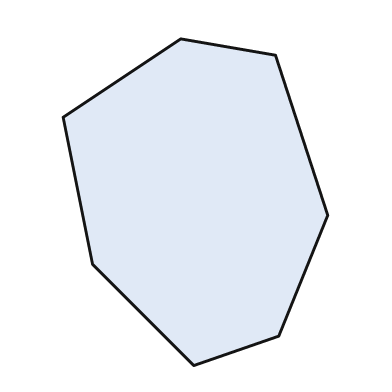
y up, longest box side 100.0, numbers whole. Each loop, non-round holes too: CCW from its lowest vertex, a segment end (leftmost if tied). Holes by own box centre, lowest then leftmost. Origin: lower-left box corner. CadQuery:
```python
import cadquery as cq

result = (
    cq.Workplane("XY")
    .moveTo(40.0, 0.0)
    .lineTo(66.0, 9.0)
    .lineTo(81.0, 46.0)
    .lineTo(65.0, 95.0)
    .lineTo(36.0, 100.0)
    .lineTo(0.0, 76.0)
    .lineTo(9.0, 31.0)
    .close()
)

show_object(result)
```